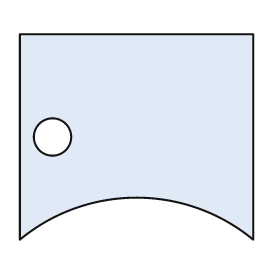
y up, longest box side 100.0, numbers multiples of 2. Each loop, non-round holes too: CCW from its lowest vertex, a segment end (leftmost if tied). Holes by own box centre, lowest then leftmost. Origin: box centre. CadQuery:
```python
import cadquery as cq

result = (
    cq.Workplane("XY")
    .moveTo(-50.0, -44.0)
    .threePointArc((0.0, -26.0), (50.0, -44.0))
    .lineTo(50.0, 44.0)
    .lineTo(-50.0, 44.0)
    .close()
    .moveTo(-36.0, 0.0)
    .circle(8.0)
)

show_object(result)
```